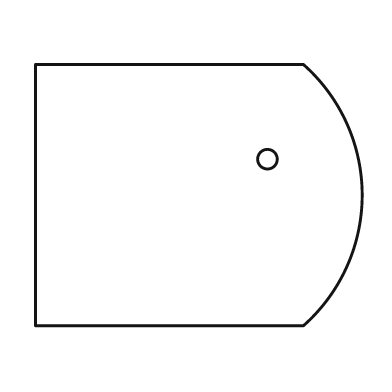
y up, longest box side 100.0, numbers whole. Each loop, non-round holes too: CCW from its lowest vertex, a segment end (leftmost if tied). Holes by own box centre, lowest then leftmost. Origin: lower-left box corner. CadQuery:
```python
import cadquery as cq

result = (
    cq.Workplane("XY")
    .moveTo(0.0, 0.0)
    .lineTo(82.0, 0.0)
    .threePointArc((100.0, 40.0), (82.0, 80.0))
    .lineTo(0.0, 80.0)
    .close()
    .moveTo(71.0, 51.0)
    .circle(3.0)
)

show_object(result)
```